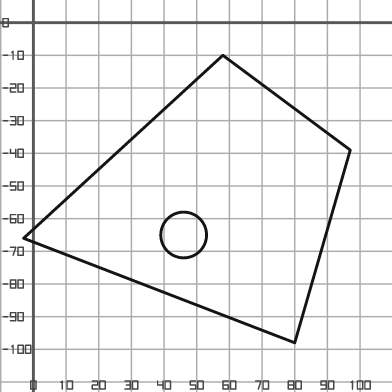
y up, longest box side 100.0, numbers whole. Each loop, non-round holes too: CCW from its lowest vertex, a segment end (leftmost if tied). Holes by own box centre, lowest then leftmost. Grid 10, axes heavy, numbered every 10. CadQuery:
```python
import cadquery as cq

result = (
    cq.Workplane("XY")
    .moveTo(80.0, -98.0)
    .lineTo(97.0, -39.0)
    .lineTo(58.0, -10.0)
    .lineTo(-3.0, -66.0)
    .close()
    .moveTo(46.0, -65.0)
    .circle(7.0)
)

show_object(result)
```